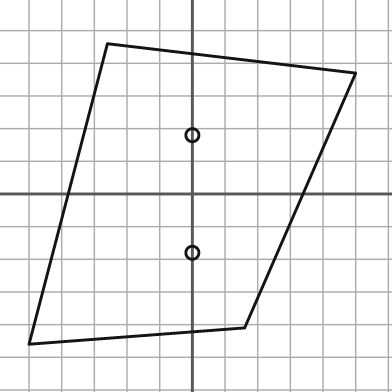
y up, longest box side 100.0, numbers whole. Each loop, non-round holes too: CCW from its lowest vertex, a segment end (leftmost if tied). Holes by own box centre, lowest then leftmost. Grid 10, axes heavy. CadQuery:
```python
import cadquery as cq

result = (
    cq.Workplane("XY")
    .moveTo(-50.0, -46.0)
    .lineTo(16.0, -41.0)
    .lineTo(50.0, 37.0)
    .lineTo(-26.0, 46.0)
    .close()
    .moveTo(0.0, -18.0)
    .circle(2.0)
    .moveTo(0.0, 18.0)
    .circle(2.0)
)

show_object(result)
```